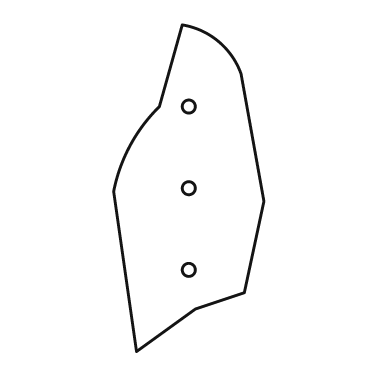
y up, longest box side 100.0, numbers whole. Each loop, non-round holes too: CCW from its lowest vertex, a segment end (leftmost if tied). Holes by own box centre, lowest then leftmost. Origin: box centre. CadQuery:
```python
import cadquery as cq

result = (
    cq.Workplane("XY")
    .moveTo(-16.0, -50.0)
    .lineTo(2.0, -37.0)
    .lineTo(17.0, -32.0)
    .lineTo(23.0, -4.0)
    .lineTo(16.0, 35.0)
    .threePointArc((9.0, 45.0), (-2.0, 50.0))
    .lineTo(-9.0, 25.0)
    .threePointArc((-18.0, 13.0), (-23.0, -1.0))
    .close()
    .moveTo(0.0, -25.0)
    .circle(2.0)
    .moveTo(0.0, 0.0)
    .circle(2.0)
    .moveTo(0.0, 25.0)
    .circle(2.0)
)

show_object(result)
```